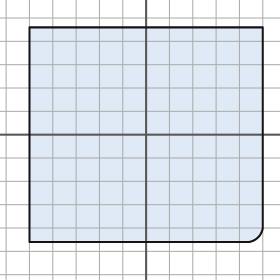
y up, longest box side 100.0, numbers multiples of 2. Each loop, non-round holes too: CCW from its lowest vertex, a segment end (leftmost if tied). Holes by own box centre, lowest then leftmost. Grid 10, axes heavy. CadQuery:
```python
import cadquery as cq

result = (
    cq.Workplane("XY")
    .moveTo(-50.0, -46.0)
    .lineTo(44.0, -46.0)
    .threePointArc((48.0, -44.0), (50.0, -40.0))
    .lineTo(50.0, 46.0)
    .lineTo(-50.0, 46.0)
    .close()
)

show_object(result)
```